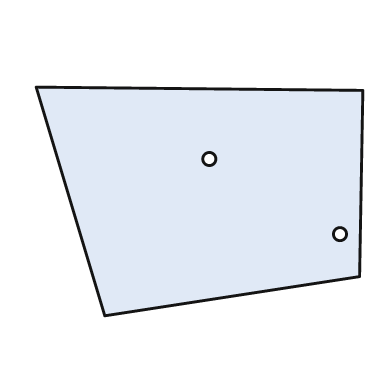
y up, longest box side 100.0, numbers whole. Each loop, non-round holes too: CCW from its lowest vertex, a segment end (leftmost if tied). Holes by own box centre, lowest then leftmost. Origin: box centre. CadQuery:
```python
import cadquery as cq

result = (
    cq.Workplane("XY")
    .moveTo(-29.0, -35.0)
    .lineTo(49.0, -23.0)
    .lineTo(50.0, 34.0)
    .lineTo(-50.0, 35.0)
    .close()
    .moveTo(43.0, -10.0)
    .circle(2.0)
    .moveTo(3.0, 13.0)
    .circle(2.0)
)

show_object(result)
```